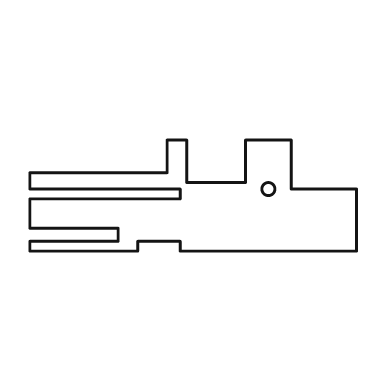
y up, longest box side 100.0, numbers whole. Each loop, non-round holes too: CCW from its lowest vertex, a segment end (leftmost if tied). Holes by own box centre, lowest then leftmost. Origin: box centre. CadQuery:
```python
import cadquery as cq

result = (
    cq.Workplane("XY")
    .moveTo(-50.0, -17.0)
    .lineTo(-17.0, -17.0)
    .lineTo(-17.0, -14.0)
    .lineTo(-4.0, -14.0)
    .lineTo(-4.0, -17.0)
    .lineTo(50.0, -17.0)
    .lineTo(50.0, 2.0)
    .lineTo(30.0, 2.0)
    .lineTo(30.0, 17.0)
    .lineTo(16.0, 17.0)
    .lineTo(16.0, 4.0)
    .lineTo(-2.0, 4.0)
    .lineTo(-2.0, 17.0)
    .lineTo(-8.0, 17.0)
    .lineTo(-8.0, 7.0)
    .lineTo(-50.0, 7.0)
    .lineTo(-50.0, 2.0)
    .lineTo(-4.0, 2.0)
    .lineTo(-4.0, -1.0)
    .lineTo(-50.0, -1.0)
    .lineTo(-50.0, -10.0)
    .lineTo(-23.0, -10.0)
    .lineTo(-23.0, -14.0)
    .lineTo(-50.0, -14.0)
    .close()
    .moveTo(23.0, 2.0)
    .circle(2.0)
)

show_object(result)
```